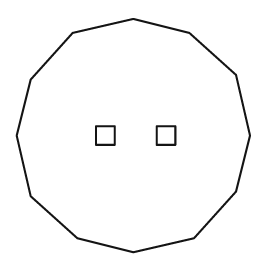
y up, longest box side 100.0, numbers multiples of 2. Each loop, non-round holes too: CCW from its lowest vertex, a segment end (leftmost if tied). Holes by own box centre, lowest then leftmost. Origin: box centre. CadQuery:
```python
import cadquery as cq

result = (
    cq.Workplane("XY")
    .moveTo(0.0, -50.0)
    .lineTo(26.0, -44.0)
    .lineTo(44.0, -24.0)
    .lineTo(50.0, 0.0)
    .lineTo(44.0, 26.0)
    .lineTo(24.0, 44.0)
    .lineTo(0.0, 50.0)
    .lineTo(-26.0, 44.0)
    .lineTo(-44.0, 24.0)
    .lineTo(-50.0, 0.0)
    .lineTo(-44.0, -26.0)
    .lineTo(-24.0, -44.0)
    .close()
    .moveTo(-16.0, -4.0)
    .lineTo(-8.0, -4.0)
    .lineTo(-8.0, 4.0)
    .lineTo(-16.0, 4.0)
    .close()
    .moveTo(10.0, -4.0)
    .lineTo(18.0, -4.0)
    .lineTo(18.0, 4.0)
    .lineTo(10.0, 4.0)
    .close()
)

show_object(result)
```